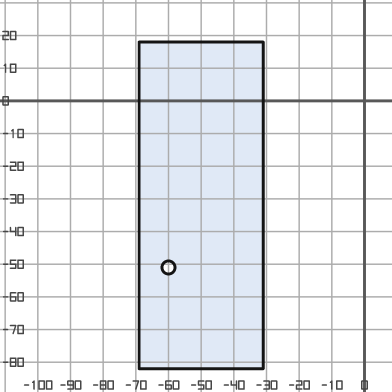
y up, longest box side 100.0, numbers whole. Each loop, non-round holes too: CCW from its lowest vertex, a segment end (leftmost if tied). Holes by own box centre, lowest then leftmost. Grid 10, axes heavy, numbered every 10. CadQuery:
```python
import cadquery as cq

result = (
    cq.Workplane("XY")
    .moveTo(-69.0, -82.0)
    .lineTo(-31.0, -82.0)
    .lineTo(-31.0, 18.0)
    .lineTo(-69.0, 18.0)
    .close()
    .moveTo(-60.0, -51.0)
    .circle(2.0)
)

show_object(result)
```